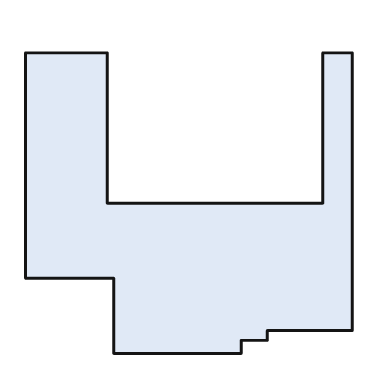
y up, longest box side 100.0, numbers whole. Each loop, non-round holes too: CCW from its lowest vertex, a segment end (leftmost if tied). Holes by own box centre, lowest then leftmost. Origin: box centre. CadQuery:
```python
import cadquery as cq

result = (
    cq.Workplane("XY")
    .moveTo(-23.0, -46.0)
    .lineTo(16.0, -46.0)
    .lineTo(16.0, -42.0)
    .lineTo(24.0, -42.0)
    .lineTo(24.0, -39.0)
    .lineTo(50.0, -39.0)
    .lineTo(50.0, 46.0)
    .lineTo(41.0, 46.0)
    .lineTo(41.0, 0.0)
    .lineTo(-25.0, 0.0)
    .lineTo(-25.0, 46.0)
    .lineTo(-50.0, 46.0)
    .lineTo(-50.0, -23.0)
    .lineTo(-23.0, -23.0)
    .close()
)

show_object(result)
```